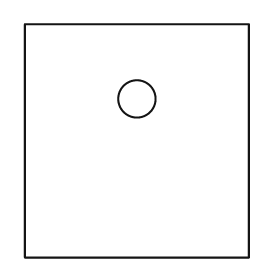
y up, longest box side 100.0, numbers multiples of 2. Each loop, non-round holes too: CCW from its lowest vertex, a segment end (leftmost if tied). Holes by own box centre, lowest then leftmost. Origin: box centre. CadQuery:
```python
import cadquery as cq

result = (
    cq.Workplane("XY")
    .moveTo(-48.0, -50.0)
    .lineTo(48.0, -50.0)
    .lineTo(48.0, 50.0)
    .lineTo(-48.0, 50.0)
    .close()
    .moveTo(0.0, 18.0)
    .circle(8.0)
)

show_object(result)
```